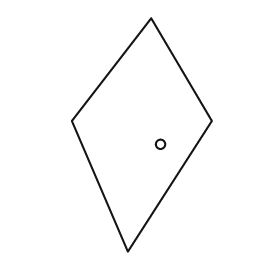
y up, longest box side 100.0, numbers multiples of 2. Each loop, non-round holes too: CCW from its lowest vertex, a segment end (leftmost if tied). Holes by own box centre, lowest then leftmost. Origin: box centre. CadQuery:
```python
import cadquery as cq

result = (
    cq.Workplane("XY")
    .moveTo(-6.0, -50.0)
    .lineTo(30.0, 6.0)
    .lineTo(4.0, 50.0)
    .lineTo(-30.0, 6.0)
    .close()
    .moveTo(8.0, -4.0)
    .circle(2.0)
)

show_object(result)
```